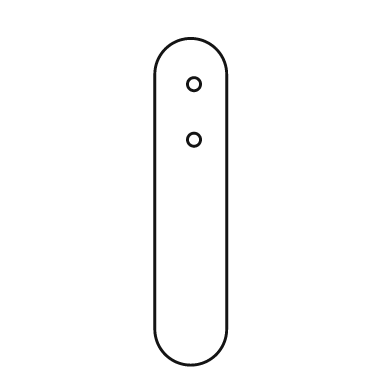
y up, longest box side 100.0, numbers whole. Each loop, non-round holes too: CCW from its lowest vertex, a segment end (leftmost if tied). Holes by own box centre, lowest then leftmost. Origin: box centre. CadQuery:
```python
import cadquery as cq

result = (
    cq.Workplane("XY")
    .moveTo(-11.0, -39.0)
    .threePointArc((0.0, -50.0), (11.0, -39.0))
    .lineTo(11.0, 39.0)
    .threePointArc((0.0, 50.0), (-11.0, 39.0))
    .close()
    .moveTo(1.0, 19.0)
    .circle(2.0)
    .moveTo(1.0, 36.0)
    .circle(2.0)
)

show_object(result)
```